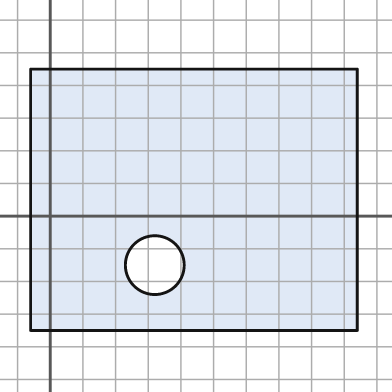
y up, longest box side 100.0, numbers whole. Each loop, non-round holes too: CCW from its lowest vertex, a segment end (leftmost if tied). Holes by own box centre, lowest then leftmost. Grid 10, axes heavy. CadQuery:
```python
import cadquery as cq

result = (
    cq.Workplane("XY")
    .moveTo(-6.0, -35.0)
    .lineTo(94.0, -35.0)
    .lineTo(94.0, 45.0)
    .lineTo(-6.0, 45.0)
    .close()
    .moveTo(32.0, -15.0)
    .circle(9.0)
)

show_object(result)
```